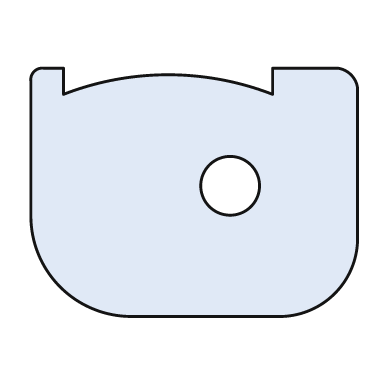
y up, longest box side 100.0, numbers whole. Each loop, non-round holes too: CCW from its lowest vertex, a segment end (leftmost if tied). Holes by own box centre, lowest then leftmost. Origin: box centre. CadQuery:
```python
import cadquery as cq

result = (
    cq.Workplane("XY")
    .moveTo(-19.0, -38.0)
    .lineTo(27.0, -38.0)
    .threePointArc((43.0, -31.0), (50.0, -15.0))
    .lineTo(50.0, 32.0)
    .threePointArc((48.0, 36.0), (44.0, 38.0))
    .lineTo(24.0, 38.0)
    .lineTo(24.0, 30.0)
    .threePointArc((-8.0, 36.0), (-40.0, 30.0))
    .lineTo(-40.0, 38.0)
    .lineTo(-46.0, 38.0)
    .threePointArc((-49.0, 37.0), (-50.0, 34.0))
    .lineTo(-50.0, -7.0)
    .threePointArc((-41.0, -29.0), (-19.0, -38.0))
    .close()
    .moveTo(11.0, 2.0)
    .circle(9.0)
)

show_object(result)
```